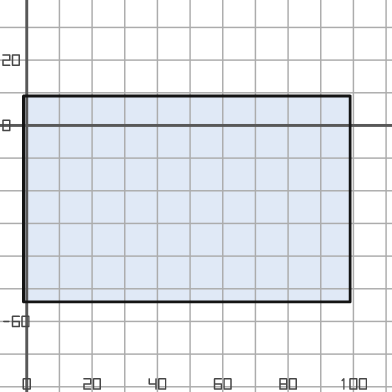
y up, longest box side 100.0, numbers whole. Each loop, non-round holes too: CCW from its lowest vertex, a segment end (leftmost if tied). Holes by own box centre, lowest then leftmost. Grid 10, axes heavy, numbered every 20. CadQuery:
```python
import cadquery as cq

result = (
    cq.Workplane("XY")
    .moveTo(-1.0, -54.0)
    .lineTo(99.0, -54.0)
    .lineTo(99.0, 9.0)
    .lineTo(-1.0, 9.0)
    .close()
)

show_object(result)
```